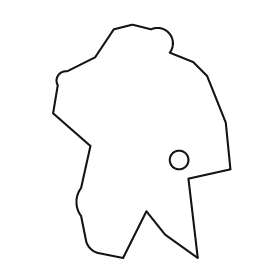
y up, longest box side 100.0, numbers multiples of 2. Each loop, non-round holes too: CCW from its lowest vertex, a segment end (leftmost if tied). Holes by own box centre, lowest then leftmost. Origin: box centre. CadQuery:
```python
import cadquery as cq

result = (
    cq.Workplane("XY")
    .moveTo(-8.0, -50.0)
    .lineTo(2.0, -30.0)
    .lineTo(10.0, -40.0)
    .lineTo(24.0, -50.0)
    .lineTo(20.0, -16.0)
    .lineTo(38.0, -12.0)
    .lineTo(36.0, 8.0)
    .lineTo(28.0, 28.0)
    .lineTo(22.0, 34.0)
    .lineTo(12.0, 38.0)
    .threePointArc((12.0, 46.0), (4.0, 48.0))
    .lineTo(-4.0, 50.0)
    .lineTo(-12.0, 48.0)
    .lineTo(-20.0, 36.0)
    .lineTo(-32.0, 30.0)
    .threePointArc((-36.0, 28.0), (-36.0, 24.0))
    .lineTo(-38.0, 12.0)
    .lineTo(-22.0, -2.0)
    .lineTo(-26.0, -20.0)
    .threePointArc((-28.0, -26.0), (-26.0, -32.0))
    .lineTo(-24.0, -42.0)
    .threePointArc((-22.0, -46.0), (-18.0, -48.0))
    .close()
    .moveTo(16.0, -8.0)
    .circle(4.0)
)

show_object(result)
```